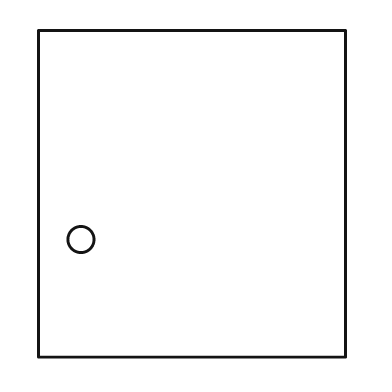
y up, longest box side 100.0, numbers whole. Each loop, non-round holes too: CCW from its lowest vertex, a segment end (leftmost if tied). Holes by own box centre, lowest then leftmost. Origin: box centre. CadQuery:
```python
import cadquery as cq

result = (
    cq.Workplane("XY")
    .moveTo(-47.0, -50.0)
    .lineTo(47.0, -50.0)
    .lineTo(47.0, 50.0)
    .lineTo(-47.0, 50.0)
    .close()
    .moveTo(-34.0, -14.0)
    .circle(4.0)
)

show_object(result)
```